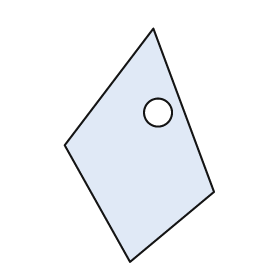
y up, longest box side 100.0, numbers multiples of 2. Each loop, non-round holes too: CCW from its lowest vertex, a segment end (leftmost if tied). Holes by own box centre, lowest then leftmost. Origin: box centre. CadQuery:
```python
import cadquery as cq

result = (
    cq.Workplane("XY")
    .moveTo(-4.0, -50.0)
    .lineTo(32.0, -20.0)
    .lineTo(6.0, 50.0)
    .lineTo(-32.0, 0.0)
    .close()
    .moveTo(8.0, 14.0)
    .circle(6.0)
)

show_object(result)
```